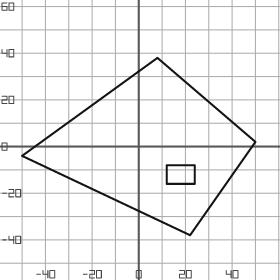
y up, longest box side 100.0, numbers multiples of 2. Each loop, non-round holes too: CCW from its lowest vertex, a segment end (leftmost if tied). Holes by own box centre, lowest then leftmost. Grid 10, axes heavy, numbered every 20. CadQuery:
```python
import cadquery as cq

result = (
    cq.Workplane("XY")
    .moveTo(22.0, -38.0)
    .lineTo(50.0, 2.0)
    .lineTo(8.0, 38.0)
    .lineTo(-50.0, -4.0)
    .close()
    .moveTo(12.0, -16.0)
    .lineTo(24.0, -16.0)
    .lineTo(24.0, -8.0)
    .lineTo(12.0, -8.0)
    .close()
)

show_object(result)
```